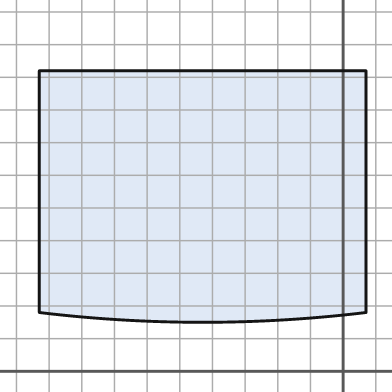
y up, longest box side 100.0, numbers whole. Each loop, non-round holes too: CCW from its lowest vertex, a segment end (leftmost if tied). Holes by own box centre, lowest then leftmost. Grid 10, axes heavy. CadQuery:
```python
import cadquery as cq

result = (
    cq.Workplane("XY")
    .moveTo(-93.0, 18.0)
    .threePointArc((-43.0, 15.0), (7.0, 18.0))
    .lineTo(7.0, 92.0)
    .lineTo(-93.0, 92.0)
    .close()
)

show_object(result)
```